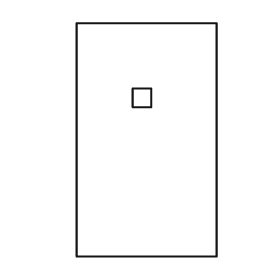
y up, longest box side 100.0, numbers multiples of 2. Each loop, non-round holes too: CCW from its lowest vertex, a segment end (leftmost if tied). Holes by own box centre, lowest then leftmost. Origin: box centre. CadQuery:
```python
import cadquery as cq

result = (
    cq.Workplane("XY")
    .moveTo(-30.0, -50.0)
    .lineTo(30.0, -50.0)
    .lineTo(30.0, 50.0)
    .lineTo(-30.0, 50.0)
    .close()
    .moveTo(-6.0, 14.0)
    .lineTo(2.0, 14.0)
    .lineTo(2.0, 22.0)
    .lineTo(-6.0, 22.0)
    .close()
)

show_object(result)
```